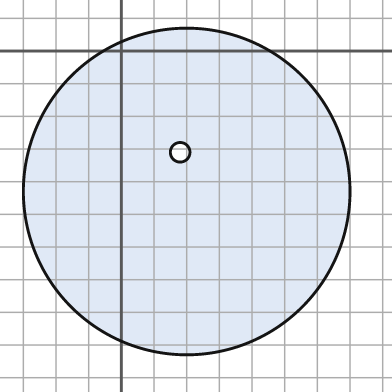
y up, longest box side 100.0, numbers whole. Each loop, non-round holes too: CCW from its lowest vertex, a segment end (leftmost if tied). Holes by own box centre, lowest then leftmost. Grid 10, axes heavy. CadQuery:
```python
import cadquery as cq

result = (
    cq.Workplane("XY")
    .moveTo(20.0, -43.0)
    .circle(50.0)
    .moveTo(18.0, -31.0)
    .circle(3.0)
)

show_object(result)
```